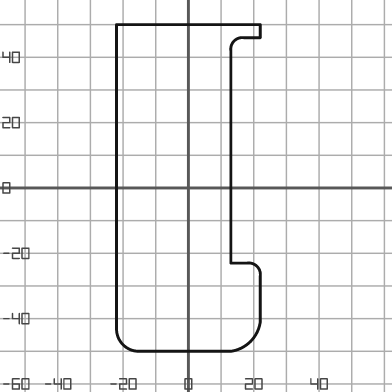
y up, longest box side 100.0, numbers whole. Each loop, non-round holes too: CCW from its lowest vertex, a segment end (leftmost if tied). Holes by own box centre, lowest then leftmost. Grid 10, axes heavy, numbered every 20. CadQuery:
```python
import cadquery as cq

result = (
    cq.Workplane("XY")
    .moveTo(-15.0, -50.0)
    .lineTo(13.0, -50.0)
    .threePointArc((19.0, -47.0), (22.0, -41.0))
    .lineTo(22.0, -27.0)
    .threePointArc((21.0, -24.0), (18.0, -23.0))
    .lineTo(13.0, -23.0)
    .lineTo(13.0, 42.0)
    .threePointArc((14.0, 45.0), (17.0, 46.0))
    .lineTo(22.0, 46.0)
    .lineTo(22.0, 50.0)
    .lineTo(-22.0, 50.0)
    .lineTo(-22.0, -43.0)
    .threePointArc((-20.0, -48.0), (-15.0, -50.0))
    .close()
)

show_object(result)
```